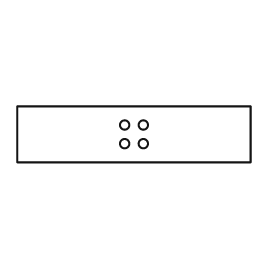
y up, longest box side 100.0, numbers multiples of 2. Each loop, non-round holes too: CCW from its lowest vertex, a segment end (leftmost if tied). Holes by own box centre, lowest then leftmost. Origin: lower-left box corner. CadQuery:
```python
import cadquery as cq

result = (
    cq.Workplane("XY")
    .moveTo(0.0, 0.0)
    .lineTo(100.0, 0.0)
    .lineTo(100.0, 24.0)
    .lineTo(0.0, 24.0)
    .close()
    .moveTo(46.0, 8.0)
    .circle(2.0)
    .moveTo(54.0, 8.0)
    .circle(2.0)
    .moveTo(46.0, 16.0)
    .circle(2.0)
    .moveTo(54.0, 16.0)
    .circle(2.0)
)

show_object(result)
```